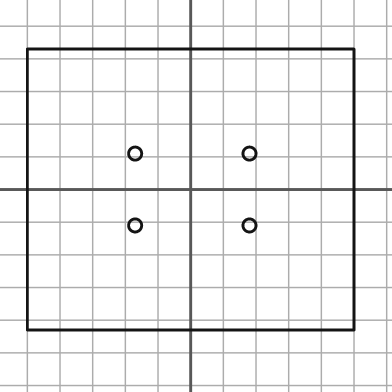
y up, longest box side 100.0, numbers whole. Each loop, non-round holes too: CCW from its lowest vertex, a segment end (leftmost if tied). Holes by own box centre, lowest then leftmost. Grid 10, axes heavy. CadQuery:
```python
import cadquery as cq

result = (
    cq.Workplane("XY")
    .moveTo(-50.0, -43.0)
    .lineTo(50.0, -43.0)
    .lineTo(50.0, 43.0)
    .lineTo(-50.0, 43.0)
    .close()
    .moveTo(-17.0, -11.0)
    .circle(2.0)
    .moveTo(18.0, -11.0)
    .circle(2.0)
    .moveTo(-17.0, 11.0)
    .circle(2.0)
    .moveTo(18.0, 11.0)
    .circle(2.0)
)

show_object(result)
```